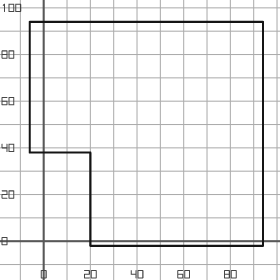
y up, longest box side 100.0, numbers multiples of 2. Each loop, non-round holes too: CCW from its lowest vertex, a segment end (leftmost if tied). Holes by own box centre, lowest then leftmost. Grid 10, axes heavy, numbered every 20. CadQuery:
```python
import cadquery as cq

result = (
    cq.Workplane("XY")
    .moveTo(20.0, -2.0)
    .lineTo(94.0, -2.0)
    .lineTo(94.0, 94.0)
    .lineTo(-6.0, 94.0)
    .lineTo(-6.0, 38.0)
    .lineTo(20.0, 38.0)
    .close()
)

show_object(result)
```